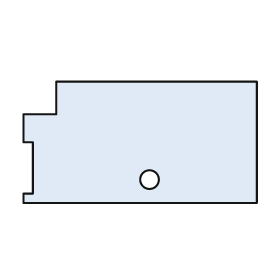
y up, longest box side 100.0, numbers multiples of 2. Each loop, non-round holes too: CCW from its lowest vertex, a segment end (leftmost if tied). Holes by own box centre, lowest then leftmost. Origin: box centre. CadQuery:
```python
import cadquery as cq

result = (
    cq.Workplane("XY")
    .moveTo(-50.0, -26.0)
    .lineTo(50.0, -26.0)
    .lineTo(50.0, 26.0)
    .lineTo(-36.0, 26.0)
    .lineTo(-36.0, 12.0)
    .lineTo(-50.0, 12.0)
    .lineTo(-50.0, 0.0)
    .lineTo(-46.0, 0.0)
    .lineTo(-46.0, -22.0)
    .lineTo(-50.0, -22.0)
    .close()
    .moveTo(4.0, -16.0)
    .circle(4.0)
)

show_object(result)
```